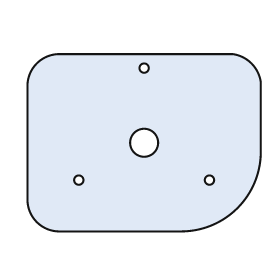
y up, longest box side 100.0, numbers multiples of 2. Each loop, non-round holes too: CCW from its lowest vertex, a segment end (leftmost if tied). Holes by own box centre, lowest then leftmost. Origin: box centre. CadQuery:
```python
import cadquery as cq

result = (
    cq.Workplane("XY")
    .moveTo(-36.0, -38.0)
    .lineTo(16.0, -38.0)
    .threePointArc((40.0, -28.0), (50.0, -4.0))
    .lineTo(50.0, 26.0)
    .threePointArc((46.0, 34.0), (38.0, 38.0))
    .lineTo(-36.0, 38.0)
    .threePointArc((-46.0, 34.0), (-50.0, 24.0))
    .lineTo(-50.0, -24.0)
    .threePointArc((-46.0, -34.0), (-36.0, -38.0))
    .close()
    .moveTo(-28.0, -16.0)
    .circle(2.0)
    .moveTo(28.0, -16.0)
    .circle(2.0)
    .moveTo(0.0, 0.0)
    .circle(6.0)
    .moveTo(0.0, 32.0)
    .circle(2.0)
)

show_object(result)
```